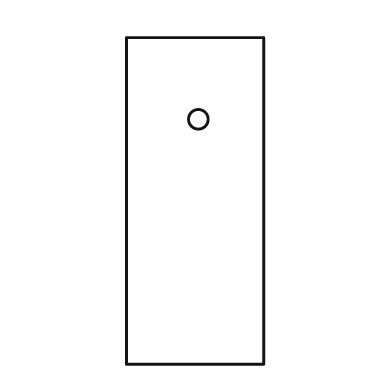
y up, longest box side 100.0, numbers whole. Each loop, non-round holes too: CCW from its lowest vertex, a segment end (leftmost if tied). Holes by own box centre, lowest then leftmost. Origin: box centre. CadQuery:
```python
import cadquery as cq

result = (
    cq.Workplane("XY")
    .moveTo(-21.0, -50.0)
    .lineTo(21.0, -50.0)
    .lineTo(21.0, 50.0)
    .lineTo(-21.0, 50.0)
    .close()
    .moveTo(1.0, 25.0)
    .circle(3.0)
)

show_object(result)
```